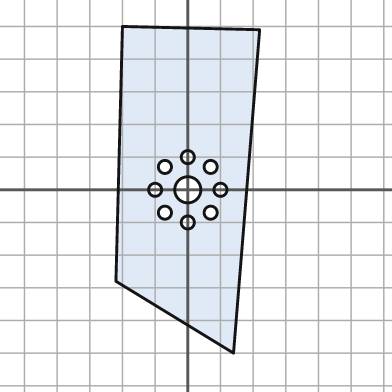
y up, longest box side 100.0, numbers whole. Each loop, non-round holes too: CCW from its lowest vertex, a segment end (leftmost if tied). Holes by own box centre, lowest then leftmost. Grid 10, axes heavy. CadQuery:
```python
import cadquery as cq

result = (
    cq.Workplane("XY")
    .moveTo(14.0, -50.0)
    .lineTo(22.0, 49.0)
    .lineTo(-20.0, 50.0)
    .lineTo(-22.0, -28.0)
    .close()
    .moveTo(0.0, -10.0)
    .circle(2.0)
    .moveTo(-7.0, -7.0)
    .circle(2.0)
    .moveTo(7.0, -7.0)
    .circle(2.0)
    .moveTo(-10.0, 0.0)
    .circle(2.0)
    .moveTo(0.0, 0.0)
    .circle(4.0)
    .moveTo(10.0, 0.0)
    .circle(2.0)
    .moveTo(-7.0, 7.0)
    .circle(2.0)
    .moveTo(7.0, 7.0)
    .circle(2.0)
    .moveTo(0.0, 10.0)
    .circle(2.0)
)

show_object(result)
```